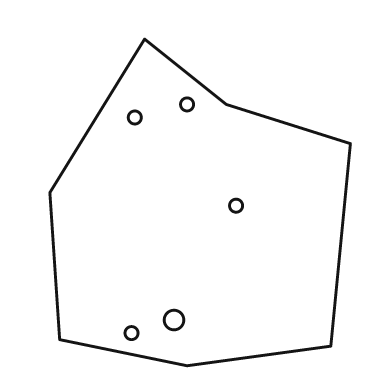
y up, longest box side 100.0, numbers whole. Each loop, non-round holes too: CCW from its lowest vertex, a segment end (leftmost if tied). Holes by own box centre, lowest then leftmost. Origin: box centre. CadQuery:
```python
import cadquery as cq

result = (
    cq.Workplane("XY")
    .moveTo(-4.0, -50.0)
    .lineTo(40.0, -44.0)
    .lineTo(46.0, 18.0)
    .lineTo(8.0, 30.0)
    .lineTo(-17.0, 50.0)
    .lineTo(-46.0, 3.0)
    .lineTo(-43.0, -42.0)
    .close()
    .moveTo(-21.0, -40.0)
    .circle(2.0)
    .moveTo(-8.0, -36.0)
    .circle(3.0)
    .moveTo(11.0, -1.0)
    .circle(2.0)
    .moveTo(-20.0, 26.0)
    .circle(2.0)
    .moveTo(-4.0, 30.0)
    .circle(2.0)
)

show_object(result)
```